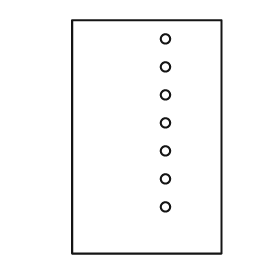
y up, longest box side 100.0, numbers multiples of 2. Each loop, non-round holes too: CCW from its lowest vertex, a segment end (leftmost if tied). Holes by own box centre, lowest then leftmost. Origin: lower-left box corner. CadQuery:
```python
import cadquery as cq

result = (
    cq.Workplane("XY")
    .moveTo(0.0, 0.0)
    .lineTo(64.0, 0.0)
    .lineTo(64.0, 100.0)
    .lineTo(0.0, 100.0)
    .close()
    .moveTo(40.0, 20.0)
    .circle(2.0)
    .moveTo(40.0, 32.0)
    .circle(2.0)
    .moveTo(40.0, 44.0)
    .circle(2.0)
    .moveTo(40.0, 56.0)
    .circle(2.0)
    .moveTo(40.0, 68.0)
    .circle(2.0)
    .moveTo(40.0, 80.0)
    .circle(2.0)
    .moveTo(40.0, 92.0)
    .circle(2.0)
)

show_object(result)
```